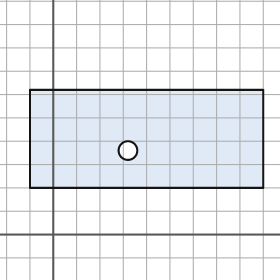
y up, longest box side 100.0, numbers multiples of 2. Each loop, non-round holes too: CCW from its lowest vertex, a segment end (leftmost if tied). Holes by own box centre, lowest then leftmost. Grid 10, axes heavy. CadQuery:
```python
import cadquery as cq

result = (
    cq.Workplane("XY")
    .moveTo(-10.0, 20.0)
    .lineTo(90.0, 20.0)
    .lineTo(90.0, 62.0)
    .lineTo(-10.0, 62.0)
    .close()
    .moveTo(32.0, 36.0)
    .circle(4.0)
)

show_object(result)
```